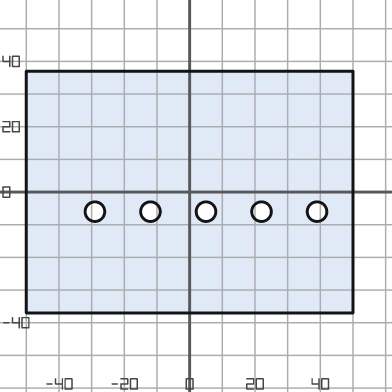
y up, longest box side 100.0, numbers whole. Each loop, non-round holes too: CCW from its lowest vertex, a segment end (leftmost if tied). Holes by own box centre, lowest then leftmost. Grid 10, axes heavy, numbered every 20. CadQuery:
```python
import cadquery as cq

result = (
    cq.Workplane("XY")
    .moveTo(-50.0, -37.0)
    .lineTo(50.0, -37.0)
    .lineTo(50.0, 37.0)
    .lineTo(-50.0, 37.0)
    .close()
    .moveTo(-29.0, -6.0)
    .circle(3.0)
    .moveTo(-12.0, -6.0)
    .circle(3.0)
    .moveTo(5.0, -6.0)
    .circle(3.0)
    .moveTo(22.0, -6.0)
    .circle(3.0)
    .moveTo(39.0, -6.0)
    .circle(3.0)
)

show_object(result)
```